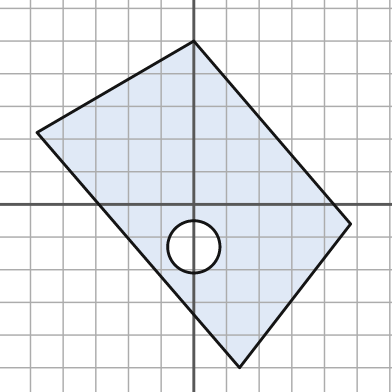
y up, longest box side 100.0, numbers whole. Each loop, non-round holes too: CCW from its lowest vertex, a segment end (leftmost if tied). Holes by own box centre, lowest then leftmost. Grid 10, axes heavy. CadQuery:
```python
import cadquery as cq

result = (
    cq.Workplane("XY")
    .moveTo(14.0, -50.0)
    .lineTo(48.0, -6.0)
    .lineTo(0.0, 50.0)
    .lineTo(-48.0, 22.0)
    .close()
    .moveTo(0.0, -13.0)
    .circle(8.0)
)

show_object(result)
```